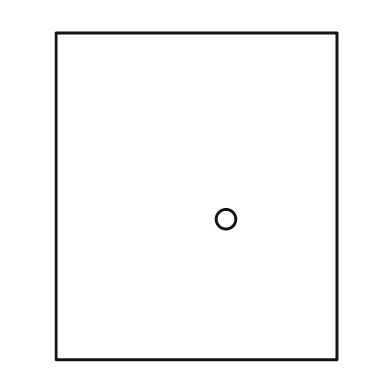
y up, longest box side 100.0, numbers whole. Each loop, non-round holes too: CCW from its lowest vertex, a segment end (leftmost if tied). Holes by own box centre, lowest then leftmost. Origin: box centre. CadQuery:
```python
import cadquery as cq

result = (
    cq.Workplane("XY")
    .moveTo(-43.0, -50.0)
    .lineTo(43.0, -50.0)
    .lineTo(43.0, 50.0)
    .lineTo(-43.0, 50.0)
    .close()
    .moveTo(9.0, -7.0)
    .circle(3.0)
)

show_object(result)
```